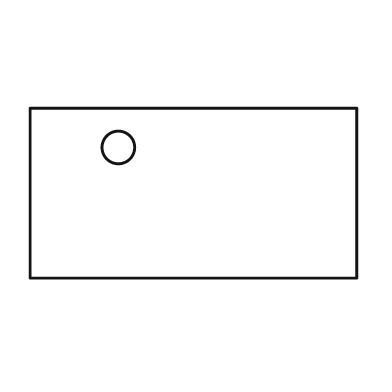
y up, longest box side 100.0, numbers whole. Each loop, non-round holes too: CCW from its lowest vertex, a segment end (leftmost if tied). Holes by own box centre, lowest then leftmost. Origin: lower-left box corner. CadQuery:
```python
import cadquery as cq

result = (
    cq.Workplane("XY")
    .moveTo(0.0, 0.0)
    .lineTo(100.0, 0.0)
    .lineTo(100.0, 52.0)
    .lineTo(0.0, 52.0)
    .close()
    .moveTo(27.0, 40.0)
    .circle(5.0)
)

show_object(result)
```